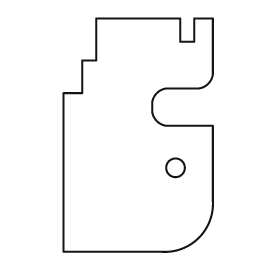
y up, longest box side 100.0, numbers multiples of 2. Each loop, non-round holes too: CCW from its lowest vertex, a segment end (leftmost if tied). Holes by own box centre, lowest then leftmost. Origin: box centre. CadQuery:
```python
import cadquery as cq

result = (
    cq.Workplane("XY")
    .moveTo(-32.0, -50.0)
    .lineTo(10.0, -50.0)
    .threePointArc((26.0, -44.0), (32.0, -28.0))
    .lineTo(32.0, 4.0)
    .lineTo(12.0, 4.0)
    .threePointArc((8.0, 6.0), (6.0, 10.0))
    .lineTo(6.0, 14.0)
    .threePointArc((8.0, 18.0), (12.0, 20.0))
    .lineTo(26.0, 20.0)
    .threePointArc((30.0, 22.0), (32.0, 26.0))
    .lineTo(32.0, 50.0)
    .lineTo(24.0, 50.0)
    .lineTo(24.0, 40.0)
    .lineTo(18.0, 40.0)
    .lineTo(18.0, 50.0)
    .lineTo(-18.0, 50.0)
    .lineTo(-18.0, 32.0)
    .lineTo(-24.0, 32.0)
    .lineTo(-24.0, 18.0)
    .lineTo(-32.0, 18.0)
    .close()
    .moveTo(16.0, -14.0)
    .circle(4.0)
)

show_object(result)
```